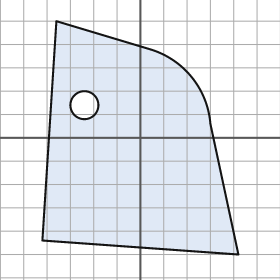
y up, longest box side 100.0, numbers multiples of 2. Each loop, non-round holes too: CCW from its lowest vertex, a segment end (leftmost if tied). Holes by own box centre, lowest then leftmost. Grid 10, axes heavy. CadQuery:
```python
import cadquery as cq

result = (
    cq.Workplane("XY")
    .moveTo(42.0, -50.0)
    .lineTo(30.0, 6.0)
    .threePointArc((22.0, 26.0), (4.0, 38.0))
    .lineTo(-36.0, 50.0)
    .lineTo(-42.0, -44.0)
    .close()
    .moveTo(-24.0, 14.0)
    .circle(6.0)
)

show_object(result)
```